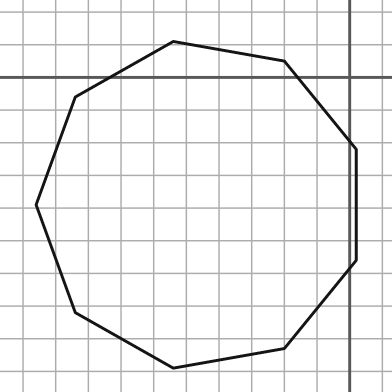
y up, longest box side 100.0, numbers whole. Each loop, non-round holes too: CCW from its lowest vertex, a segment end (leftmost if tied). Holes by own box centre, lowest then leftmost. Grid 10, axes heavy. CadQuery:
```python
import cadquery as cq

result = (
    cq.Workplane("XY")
    .moveTo(-54.0, -89.0)
    .lineTo(-20.0, -83.0)
    .lineTo(2.0, -56.0)
    .lineTo(2.0, -22.0)
    .lineTo(-20.0, 5.0)
    .lineTo(-54.0, 11.0)
    .lineTo(-84.0, -6.0)
    .lineTo(-96.0, -39.0)
    .lineTo(-84.0, -72.0)
    .close()
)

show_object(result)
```